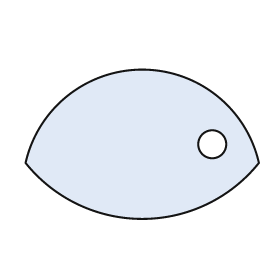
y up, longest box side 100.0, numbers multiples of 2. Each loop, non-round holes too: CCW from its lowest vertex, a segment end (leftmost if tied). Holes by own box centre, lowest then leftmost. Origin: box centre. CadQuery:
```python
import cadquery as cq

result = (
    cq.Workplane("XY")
    .moveTo(-50.0, -8.0)
    .threePointArc((0.0, -32.0), (50.0, -8.0))
    .threePointArc((0.0, 32.0), (-50.0, -8.0))
    .close()
    .moveTo(30.0, 0.0)
    .circle(6.0)
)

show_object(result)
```